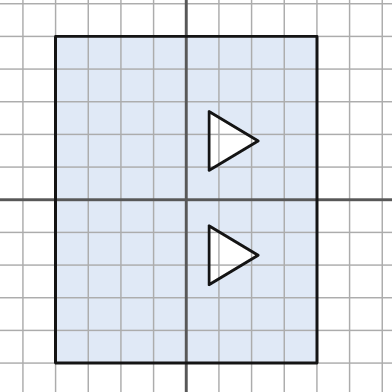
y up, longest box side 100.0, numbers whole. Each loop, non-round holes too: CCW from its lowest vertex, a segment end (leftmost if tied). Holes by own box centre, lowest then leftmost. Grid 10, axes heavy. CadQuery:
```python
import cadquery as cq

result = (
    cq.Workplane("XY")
    .moveTo(-40.0, -50.0)
    .lineTo(40.0, -50.0)
    .lineTo(40.0, 50.0)
    .lineTo(-40.0, 50.0)
    .close()
    .moveTo(7.0, -26.0)
    .lineTo(22.0, -17.0)
    .lineTo(7.0, -8.0)
    .close()
    .moveTo(7.0, 9.0)
    .lineTo(22.0, 18.0)
    .lineTo(7.0, 27.0)
    .close()
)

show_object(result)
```